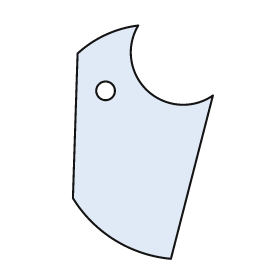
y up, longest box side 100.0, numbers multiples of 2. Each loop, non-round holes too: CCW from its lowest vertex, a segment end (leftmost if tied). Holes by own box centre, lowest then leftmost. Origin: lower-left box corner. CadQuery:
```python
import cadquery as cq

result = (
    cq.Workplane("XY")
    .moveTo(42.0, 0.0)
    .lineTo(60.0, 70.0)
    .threePointArc((32.0, 72.0), (28.0, 100.0))
    .threePointArc((14.0, 96.0), (2.0, 88.0))
    .lineTo(0.0, 26.0)
    .threePointArc((18.0, 8.0), (42.0, 0.0))
    .close()
    .moveTo(14.0, 72.0)
    .circle(4.0)
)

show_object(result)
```